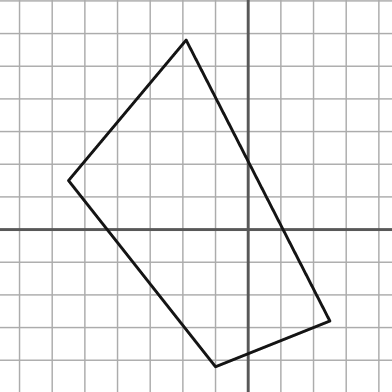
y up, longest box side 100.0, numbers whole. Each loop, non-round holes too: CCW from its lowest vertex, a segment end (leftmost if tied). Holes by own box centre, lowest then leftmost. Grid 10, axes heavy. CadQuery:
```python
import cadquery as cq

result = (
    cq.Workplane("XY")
    .moveTo(-10.0, -42.0)
    .lineTo(25.0, -28.0)
    .lineTo(-19.0, 58.0)
    .lineTo(-55.0, 15.0)
    .close()
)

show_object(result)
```